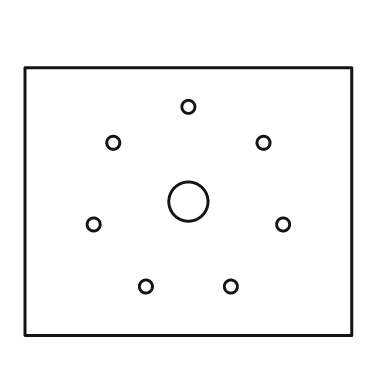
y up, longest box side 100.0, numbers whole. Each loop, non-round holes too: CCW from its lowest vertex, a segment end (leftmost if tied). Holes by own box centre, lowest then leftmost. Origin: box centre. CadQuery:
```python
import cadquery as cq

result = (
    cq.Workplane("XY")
    .moveTo(-50.0, -41.0)
    .lineTo(50.0, -41.0)
    .lineTo(50.0, 41.0)
    .lineTo(-50.0, 41.0)
    .close()
    .moveTo(-13.0, -26.0)
    .circle(2.0)
    .moveTo(13.0, -26.0)
    .circle(2.0)
    .moveTo(-29.0, -7.0)
    .circle(2.0)
    .moveTo(29.0, -7.0)
    .circle(2.0)
    .moveTo(0.0, 0.0)
    .circle(6.0)
    .moveTo(-23.0, 18.0)
    .circle(2.0)
    .moveTo(23.0, 18.0)
    .circle(2.0)
    .moveTo(0.0, 29.0)
    .circle(2.0)
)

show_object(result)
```